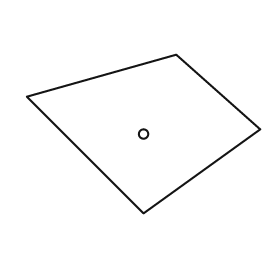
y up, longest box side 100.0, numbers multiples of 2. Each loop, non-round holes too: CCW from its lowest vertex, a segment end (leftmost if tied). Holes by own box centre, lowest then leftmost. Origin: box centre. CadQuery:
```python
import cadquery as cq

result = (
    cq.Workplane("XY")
    .moveTo(0.0, -34.0)
    .lineTo(50.0, 2.0)
    .lineTo(14.0, 34.0)
    .lineTo(-50.0, 16.0)
    .close()
    .moveTo(0.0, 0.0)
    .circle(2.0)
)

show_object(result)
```